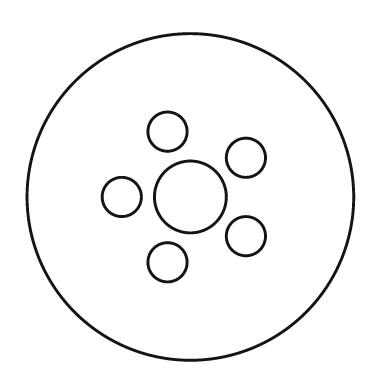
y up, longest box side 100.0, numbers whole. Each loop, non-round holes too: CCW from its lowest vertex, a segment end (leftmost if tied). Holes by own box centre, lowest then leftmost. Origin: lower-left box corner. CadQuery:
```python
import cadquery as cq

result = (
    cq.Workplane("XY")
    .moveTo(50.0, 50.0)
    .circle(50.0)
    .moveTo(43.0, 30.0)
    .circle(6.0)
    .moveTo(67.0, 38.0)
    .circle(6.0)
    .moveTo(29.0, 50.0)
    .circle(6.0)
    .moveTo(50.0, 50.0)
    .circle(11.0)
    .moveTo(67.0, 62.0)
    .circle(6.0)
    .moveTo(43.0, 70.0)
    .circle(6.0)
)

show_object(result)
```